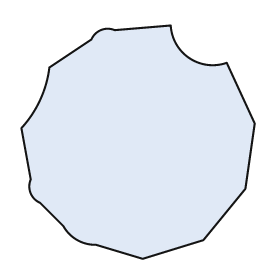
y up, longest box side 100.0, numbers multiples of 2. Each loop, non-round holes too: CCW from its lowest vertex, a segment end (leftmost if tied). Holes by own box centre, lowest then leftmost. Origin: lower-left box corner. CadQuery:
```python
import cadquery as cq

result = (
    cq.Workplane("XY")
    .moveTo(52.0, 0.0)
    .lineTo(78.0, 8.0)
    .lineTo(96.0, 30.0)
    .lineTo(100.0, 58.0)
    .lineTo(88.0, 84.0)
    .threePointArc((72.0, 86.0), (64.0, 100.0))
    .lineTo(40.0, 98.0)
    .threePointArc((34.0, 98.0), (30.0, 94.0))
    .lineTo(12.0, 82.0)
    .threePointArc((8.0, 68.0), (0.0, 56.0))
    .lineTo(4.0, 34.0)
    .threePointArc((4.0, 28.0), (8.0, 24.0))
    .lineTo(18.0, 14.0)
    .threePointArc((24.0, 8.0), (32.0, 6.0))
    .close()
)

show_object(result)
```